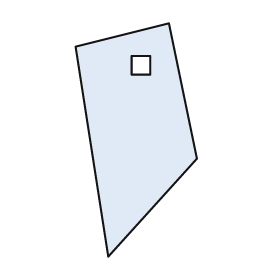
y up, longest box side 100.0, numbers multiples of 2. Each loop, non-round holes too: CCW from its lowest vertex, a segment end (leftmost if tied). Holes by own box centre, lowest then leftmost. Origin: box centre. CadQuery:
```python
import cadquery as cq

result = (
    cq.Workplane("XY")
    .moveTo(-12.0, -50.0)
    .lineTo(26.0, -8.0)
    .lineTo(14.0, 50.0)
    .lineTo(-26.0, 40.0)
    .close()
    .moveTo(-2.0, 28.0)
    .lineTo(6.0, 28.0)
    .lineTo(6.0, 36.0)
    .lineTo(-2.0, 36.0)
    .close()
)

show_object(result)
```